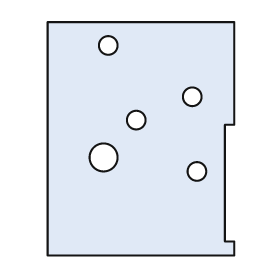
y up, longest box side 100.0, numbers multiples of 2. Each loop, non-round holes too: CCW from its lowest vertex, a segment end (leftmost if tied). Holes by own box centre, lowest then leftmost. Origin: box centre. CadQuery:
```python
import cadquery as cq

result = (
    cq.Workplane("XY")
    .moveTo(-40.0, -50.0)
    .lineTo(40.0, -50.0)
    .lineTo(40.0, -44.0)
    .lineTo(36.0, -44.0)
    .lineTo(36.0, 6.0)
    .lineTo(40.0, 6.0)
    .lineTo(40.0, 50.0)
    .lineTo(-40.0, 50.0)
    .close()
    .moveTo(24.0, -14.0)
    .circle(4.0)
    .moveTo(-16.0, -8.0)
    .circle(6.0)
    .moveTo(-2.0, 8.0)
    .circle(4.0)
    .moveTo(22.0, 18.0)
    .circle(4.0)
    .moveTo(-14.0, 40.0)
    .circle(4.0)
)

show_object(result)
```